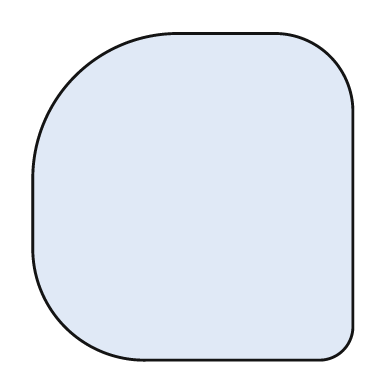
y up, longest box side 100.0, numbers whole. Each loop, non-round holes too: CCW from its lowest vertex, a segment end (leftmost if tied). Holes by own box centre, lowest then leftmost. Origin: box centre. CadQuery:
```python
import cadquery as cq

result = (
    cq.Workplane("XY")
    .moveTo(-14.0, -50.0)
    .lineTo(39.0, -50.0)
    .threePointArc((46.0, -47.0), (49.0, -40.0))
    .lineTo(49.0, 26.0)
    .threePointArc((42.0, 43.0), (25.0, 50.0))
    .lineTo(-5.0, 50.0)
    .threePointArc((-36.0, 37.0), (-49.0, 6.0))
    .lineTo(-49.0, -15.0)
    .threePointArc((-39.0, -40.0), (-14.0, -50.0))
    .close()
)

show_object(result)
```